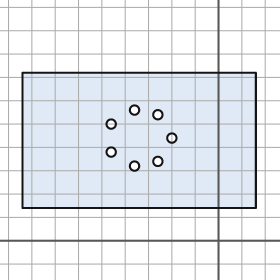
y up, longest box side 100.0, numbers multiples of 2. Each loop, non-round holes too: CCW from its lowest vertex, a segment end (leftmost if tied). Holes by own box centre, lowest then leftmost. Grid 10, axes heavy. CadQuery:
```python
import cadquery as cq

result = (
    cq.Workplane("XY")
    .moveTo(-84.0, 14.0)
    .lineTo(16.0, 14.0)
    .lineTo(16.0, 72.0)
    .lineTo(-84.0, 72.0)
    .close()
    .moveTo(-36.0, 32.0)
    .circle(2.0)
    .moveTo(-26.0, 34.0)
    .circle(2.0)
    .moveTo(-46.0, 38.0)
    .circle(2.0)
    .moveTo(-20.0, 44.0)
    .circle(2.0)
    .moveTo(-46.0, 50.0)
    .circle(2.0)
    .moveTo(-26.0, 54.0)
    .circle(2.0)
    .moveTo(-36.0, 56.0)
    .circle(2.0)
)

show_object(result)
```